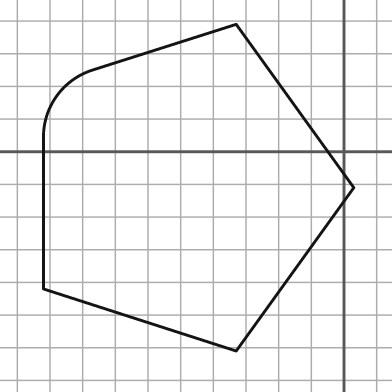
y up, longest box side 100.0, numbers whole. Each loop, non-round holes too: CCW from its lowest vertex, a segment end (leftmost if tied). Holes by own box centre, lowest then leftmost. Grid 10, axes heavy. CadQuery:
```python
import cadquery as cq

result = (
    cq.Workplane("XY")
    .moveTo(-33.0, -61.0)
    .lineTo(3.0, -11.0)
    .lineTo(-33.0, 39.0)
    .lineTo(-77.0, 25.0)
    .threePointArc((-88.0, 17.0), (-92.0, 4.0))
    .lineTo(-92.0, -42.0)
    .close()
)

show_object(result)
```